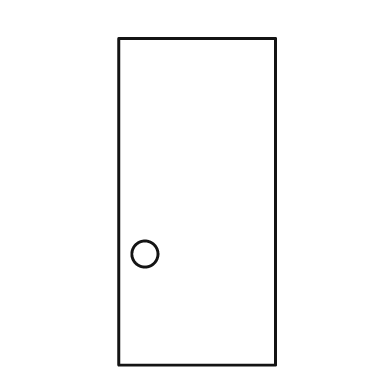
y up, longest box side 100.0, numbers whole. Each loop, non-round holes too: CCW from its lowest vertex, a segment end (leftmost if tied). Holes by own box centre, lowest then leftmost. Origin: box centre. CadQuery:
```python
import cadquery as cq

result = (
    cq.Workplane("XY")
    .moveTo(-24.0, -50.0)
    .lineTo(24.0, -50.0)
    .lineTo(24.0, 50.0)
    .lineTo(-24.0, 50.0)
    .close()
    .moveTo(-16.0, -16.0)
    .circle(4.0)
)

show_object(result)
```